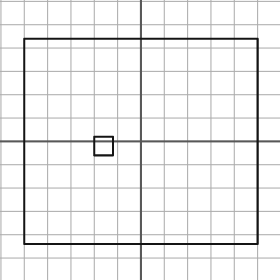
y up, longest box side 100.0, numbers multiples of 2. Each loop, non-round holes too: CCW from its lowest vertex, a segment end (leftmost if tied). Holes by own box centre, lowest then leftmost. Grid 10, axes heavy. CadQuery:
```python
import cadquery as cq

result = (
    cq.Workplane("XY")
    .moveTo(-50.0, -44.0)
    .lineTo(50.0, -44.0)
    .lineTo(50.0, 44.0)
    .lineTo(-50.0, 44.0)
    .close()
    .moveTo(-20.0, -6.0)
    .lineTo(-12.0, -6.0)
    .lineTo(-12.0, 2.0)
    .lineTo(-20.0, 2.0)
    .close()
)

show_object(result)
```